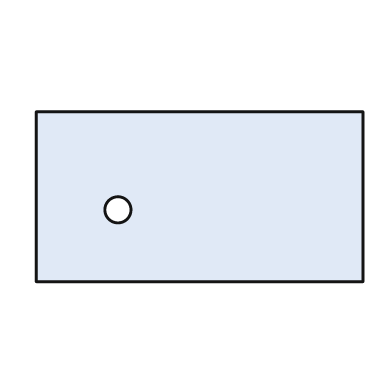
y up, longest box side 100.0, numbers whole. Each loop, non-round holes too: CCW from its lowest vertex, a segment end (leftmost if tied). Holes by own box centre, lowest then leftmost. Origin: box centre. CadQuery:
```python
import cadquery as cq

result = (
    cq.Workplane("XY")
    .moveTo(-50.0, -26.0)
    .lineTo(50.0, -26.0)
    .lineTo(50.0, 26.0)
    .lineTo(-50.0, 26.0)
    .close()
    .moveTo(-25.0, -4.0)
    .circle(4.0)
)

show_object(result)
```